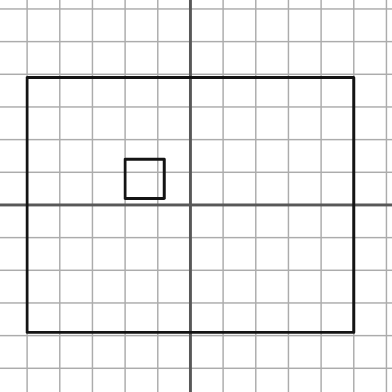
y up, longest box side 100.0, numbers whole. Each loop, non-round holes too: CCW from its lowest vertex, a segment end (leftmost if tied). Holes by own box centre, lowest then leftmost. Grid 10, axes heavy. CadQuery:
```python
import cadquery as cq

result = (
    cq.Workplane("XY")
    .moveTo(-50.0, -39.0)
    .lineTo(50.0, -39.0)
    .lineTo(50.0, 39.0)
    .lineTo(-50.0, 39.0)
    .close()
    .moveTo(-20.0, 2.0)
    .lineTo(-8.0, 2.0)
    .lineTo(-8.0, 14.0)
    .lineTo(-20.0, 14.0)
    .close()
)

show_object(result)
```